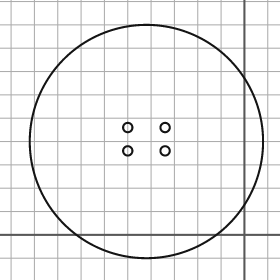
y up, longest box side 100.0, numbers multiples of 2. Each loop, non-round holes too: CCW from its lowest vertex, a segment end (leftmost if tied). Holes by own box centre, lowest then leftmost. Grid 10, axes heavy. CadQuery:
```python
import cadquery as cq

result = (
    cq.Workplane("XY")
    .moveTo(-42.0, 40.0)
    .circle(50.0)
    .moveTo(-50.0, 36.0)
    .circle(2.0)
    .moveTo(-34.0, 36.0)
    .circle(2.0)
    .moveTo(-50.0, 46.0)
    .circle(2.0)
    .moveTo(-34.0, 46.0)
    .circle(2.0)
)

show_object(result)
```